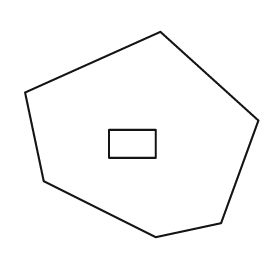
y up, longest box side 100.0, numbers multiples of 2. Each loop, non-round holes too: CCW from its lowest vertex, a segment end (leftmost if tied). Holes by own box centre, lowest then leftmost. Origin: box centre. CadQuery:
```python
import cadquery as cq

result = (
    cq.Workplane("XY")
    .moveTo(6.0, -44.0)
    .lineTo(34.0, -38.0)
    .lineTo(50.0, 6.0)
    .lineTo(8.0, 44.0)
    .lineTo(-50.0, 18.0)
    .lineTo(-42.0, -20.0)
    .close()
    .moveTo(-14.0, -10.0)
    .lineTo(6.0, -10.0)
    .lineTo(6.0, 2.0)
    .lineTo(-14.0, 2.0)
    .close()
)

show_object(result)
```